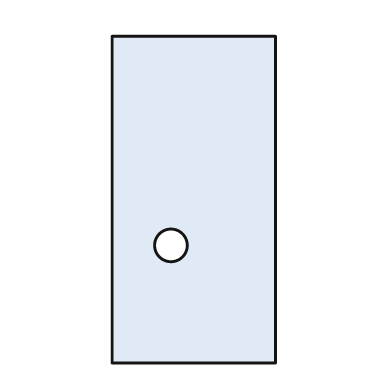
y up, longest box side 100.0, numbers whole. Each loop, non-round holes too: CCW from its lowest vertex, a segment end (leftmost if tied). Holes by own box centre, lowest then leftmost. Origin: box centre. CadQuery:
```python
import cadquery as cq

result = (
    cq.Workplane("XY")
    .moveTo(-25.0, -50.0)
    .lineTo(25.0, -50.0)
    .lineTo(25.0, 50.0)
    .lineTo(-25.0, 50.0)
    .close()
    .moveTo(-7.0, -14.0)
    .circle(5.0)
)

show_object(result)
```